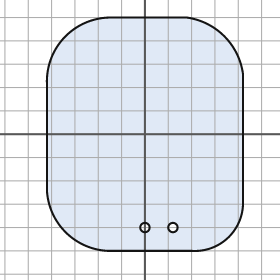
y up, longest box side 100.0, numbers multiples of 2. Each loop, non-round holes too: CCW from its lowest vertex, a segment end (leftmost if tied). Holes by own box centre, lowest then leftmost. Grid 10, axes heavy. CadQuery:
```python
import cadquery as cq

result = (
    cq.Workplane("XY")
    .moveTo(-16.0, -50.0)
    .lineTo(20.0, -50.0)
    .threePointArc((36.0, -44.0), (42.0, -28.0))
    .lineTo(42.0, 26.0)
    .threePointArc((34.0, 42.0), (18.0, 50.0))
    .lineTo(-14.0, 50.0)
    .threePointArc((-34.0, 42.0), (-42.0, 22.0))
    .lineTo(-42.0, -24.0)
    .threePointArc((-34.0, -42.0), (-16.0, -50.0))
    .close()
    .moveTo(0.0, -40.0)
    .circle(2.0)
    .moveTo(12.0, -40.0)
    .circle(2.0)
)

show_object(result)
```